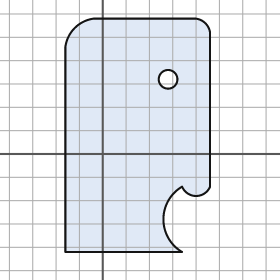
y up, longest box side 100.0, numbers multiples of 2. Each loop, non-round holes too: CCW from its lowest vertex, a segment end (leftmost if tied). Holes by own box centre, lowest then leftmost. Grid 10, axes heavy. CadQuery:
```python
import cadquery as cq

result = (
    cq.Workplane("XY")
    .moveTo(-16.0, -42.0)
    .lineTo(34.0, -42.0)
    .threePointArc((26.0, -28.0), (34.0, -14.0))
    .threePointArc((40.0, -18.0), (46.0, -14.0))
    .lineTo(46.0, 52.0)
    .threePointArc((44.0, 56.0), (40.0, 58.0))
    .lineTo(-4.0, 58.0)
    .threePointArc((-12.0, 54.0), (-16.0, 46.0))
    .close()
    .moveTo(28.0, 32.0)
    .circle(4.0)
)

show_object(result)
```